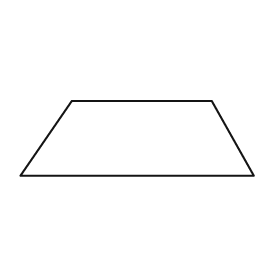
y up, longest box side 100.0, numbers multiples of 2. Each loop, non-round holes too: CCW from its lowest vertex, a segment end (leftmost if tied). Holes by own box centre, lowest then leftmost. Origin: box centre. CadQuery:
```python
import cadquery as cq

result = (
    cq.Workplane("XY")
    .moveTo(-50.0, -16.0)
    .lineTo(50.0, -16.0)
    .lineTo(32.0, 16.0)
    .lineTo(-28.0, 16.0)
    .close()
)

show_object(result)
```